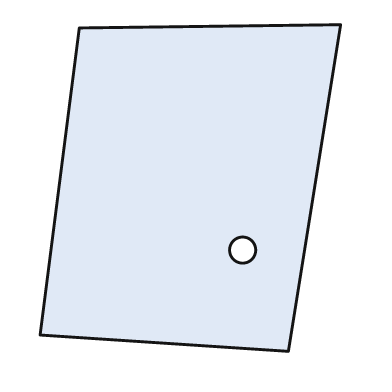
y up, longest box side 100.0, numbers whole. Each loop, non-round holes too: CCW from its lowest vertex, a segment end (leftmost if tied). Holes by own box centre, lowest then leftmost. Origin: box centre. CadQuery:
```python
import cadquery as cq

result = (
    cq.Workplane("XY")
    .moveTo(30.0, -50.0)
    .lineTo(46.0, 50.0)
    .lineTo(-34.0, 49.0)
    .lineTo(-46.0, -45.0)
    .close()
    .moveTo(16.0, -19.0)
    .circle(4.0)
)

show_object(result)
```